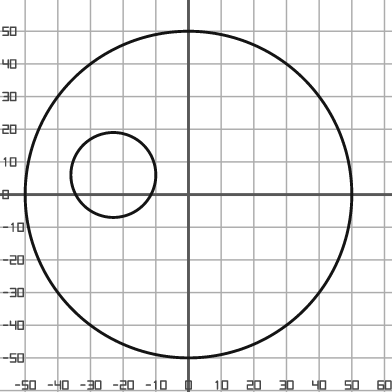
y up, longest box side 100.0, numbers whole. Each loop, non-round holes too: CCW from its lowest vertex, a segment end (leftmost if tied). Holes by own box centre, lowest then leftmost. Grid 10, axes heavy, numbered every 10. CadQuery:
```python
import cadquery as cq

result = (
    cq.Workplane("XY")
    .moveTo(0.0, 0.0)
    .circle(50.0)
    .moveTo(-23.0, 6.0)
    .circle(13.0)
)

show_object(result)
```